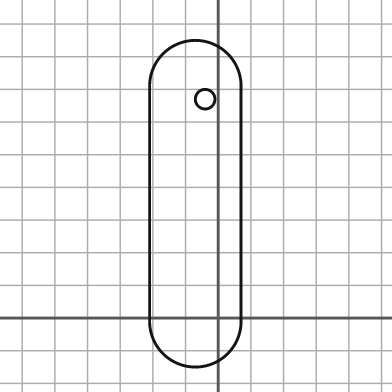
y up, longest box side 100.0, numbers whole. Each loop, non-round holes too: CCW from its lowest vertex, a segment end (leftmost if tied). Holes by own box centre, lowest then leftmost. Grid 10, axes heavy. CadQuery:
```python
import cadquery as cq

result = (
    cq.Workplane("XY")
    .moveTo(-21.0, -1.0)
    .threePointArc((-7.0, -15.0), (7.0, -1.0))
    .lineTo(7.0, 71.0)
    .threePointArc((-7.0, 85.0), (-21.0, 71.0))
    .close()
    .moveTo(-4.0, 67.0)
    .circle(3.0)
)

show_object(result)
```